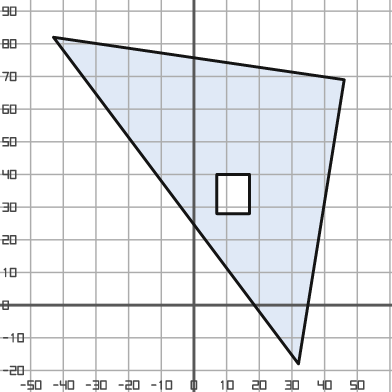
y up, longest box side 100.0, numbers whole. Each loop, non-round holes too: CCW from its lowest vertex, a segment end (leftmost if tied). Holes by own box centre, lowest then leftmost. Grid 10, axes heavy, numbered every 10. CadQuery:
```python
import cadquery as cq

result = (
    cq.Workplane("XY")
    .moveTo(32.0, -18.0)
    .lineTo(46.0, 69.0)
    .lineTo(-43.0, 82.0)
    .close()
    .moveTo(7.0, 28.0)
    .lineTo(17.0, 28.0)
    .lineTo(17.0, 40.0)
    .lineTo(7.0, 40.0)
    .close()
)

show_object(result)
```